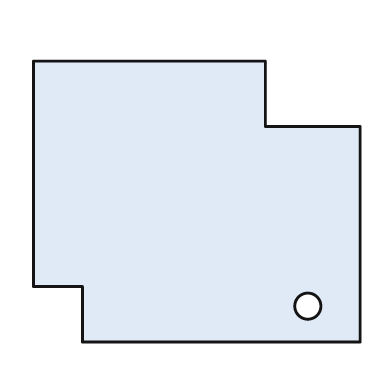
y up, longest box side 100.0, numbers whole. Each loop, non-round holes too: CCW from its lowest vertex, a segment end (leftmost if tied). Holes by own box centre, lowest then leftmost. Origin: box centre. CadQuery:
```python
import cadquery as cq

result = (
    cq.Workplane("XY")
    .moveTo(-35.0, -43.0)
    .lineTo(50.0, -43.0)
    .lineTo(50.0, 23.0)
    .lineTo(21.0, 23.0)
    .lineTo(21.0, 43.0)
    .lineTo(-50.0, 43.0)
    .lineTo(-50.0, -26.0)
    .lineTo(-35.0, -26.0)
    .close()
    .moveTo(34.0, -32.0)
    .circle(4.0)
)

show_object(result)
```